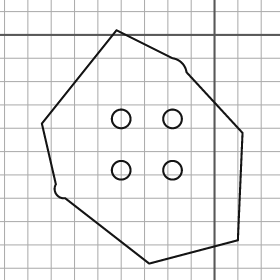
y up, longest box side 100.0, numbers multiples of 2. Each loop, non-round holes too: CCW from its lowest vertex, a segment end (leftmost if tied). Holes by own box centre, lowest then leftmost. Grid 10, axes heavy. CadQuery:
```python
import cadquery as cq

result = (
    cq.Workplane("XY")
    .moveTo(-28.0, -98.0)
    .lineTo(10.0, -88.0)
    .lineTo(12.0, -42.0)
    .lineTo(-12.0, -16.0)
    .threePointArc((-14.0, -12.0), (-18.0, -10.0))
    .lineTo(-42.0, 2.0)
    .lineTo(-74.0, -38.0)
    .lineTo(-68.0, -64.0)
    .threePointArc((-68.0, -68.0), (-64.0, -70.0))
    .close()
    .moveTo(-40.0, -58.0)
    .circle(4.0)
    .moveTo(-18.0, -58.0)
    .circle(4.0)
    .moveTo(-40.0, -36.0)
    .circle(4.0)
    .moveTo(-18.0, -36.0)
    .circle(4.0)
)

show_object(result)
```